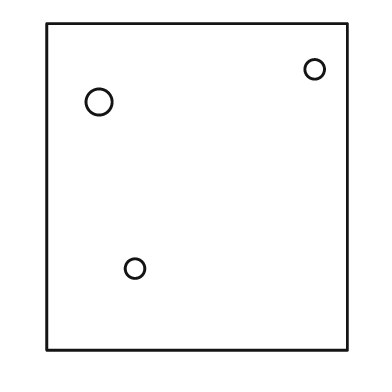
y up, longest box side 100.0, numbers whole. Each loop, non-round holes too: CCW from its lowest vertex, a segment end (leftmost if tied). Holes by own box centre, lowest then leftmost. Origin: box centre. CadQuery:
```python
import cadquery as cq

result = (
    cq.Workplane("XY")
    .moveTo(-46.0, -50.0)
    .lineTo(46.0, -50.0)
    .lineTo(46.0, 50.0)
    .lineTo(-46.0, 50.0)
    .close()
    .moveTo(-19.0, -25.0)
    .circle(3.0)
    .moveTo(-30.0, 26.0)
    .circle(4.0)
    .moveTo(36.0, 36.0)
    .circle(3.0)
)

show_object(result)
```